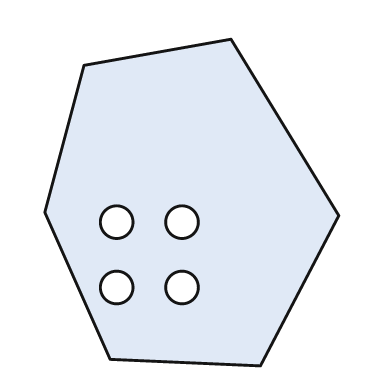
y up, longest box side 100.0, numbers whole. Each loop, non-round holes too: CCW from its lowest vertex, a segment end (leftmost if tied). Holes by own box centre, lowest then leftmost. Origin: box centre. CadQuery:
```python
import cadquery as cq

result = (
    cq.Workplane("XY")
    .moveTo(21.0, -50.0)
    .lineTo(45.0, -4.0)
    .lineTo(12.0, 50.0)
    .lineTo(-33.0, 42.0)
    .lineTo(-45.0, -3.0)
    .lineTo(-25.0, -48.0)
    .close()
    .moveTo(-23.0, -26.0)
    .circle(5.0)
    .moveTo(-3.0, -26.0)
    .circle(5.0)
    .moveTo(-23.0, -6.0)
    .circle(5.0)
    .moveTo(-3.0, -6.0)
    .circle(5.0)
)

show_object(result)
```